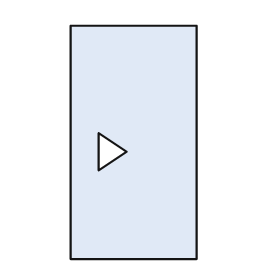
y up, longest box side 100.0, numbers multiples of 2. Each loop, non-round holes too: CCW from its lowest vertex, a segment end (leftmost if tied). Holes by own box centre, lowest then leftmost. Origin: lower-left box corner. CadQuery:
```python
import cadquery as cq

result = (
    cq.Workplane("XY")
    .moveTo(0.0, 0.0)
    .lineTo(54.0, 0.0)
    .lineTo(54.0, 100.0)
    .lineTo(0.0, 100.0)
    .close()
    .moveTo(12.0, 38.0)
    .lineTo(24.0, 46.0)
    .lineTo(12.0, 54.0)
    .close()
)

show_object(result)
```